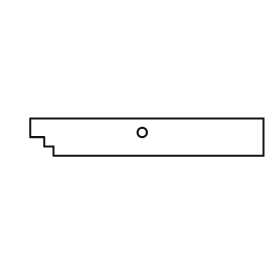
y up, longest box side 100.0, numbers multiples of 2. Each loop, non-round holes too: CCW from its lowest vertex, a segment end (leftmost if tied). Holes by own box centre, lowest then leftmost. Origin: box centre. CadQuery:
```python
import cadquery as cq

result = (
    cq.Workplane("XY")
    .moveTo(-40.0, -8.0)
    .lineTo(50.0, -8.0)
    .lineTo(50.0, 8.0)
    .lineTo(-50.0, 8.0)
    .lineTo(-50.0, 0.0)
    .lineTo(-44.0, 0.0)
    .lineTo(-44.0, -4.0)
    .lineTo(-40.0, -4.0)
    .close()
    .moveTo(-2.0, 2.0)
    .circle(2.0)
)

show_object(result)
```